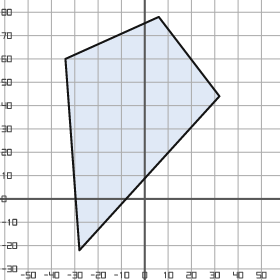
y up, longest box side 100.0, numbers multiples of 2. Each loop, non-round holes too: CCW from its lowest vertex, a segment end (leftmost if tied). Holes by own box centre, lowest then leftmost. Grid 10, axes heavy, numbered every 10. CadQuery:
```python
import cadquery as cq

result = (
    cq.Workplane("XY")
    .moveTo(-28.0, -22.0)
    .lineTo(32.0, 44.0)
    .lineTo(6.0, 78.0)
    .lineTo(-34.0, 60.0)
    .close()
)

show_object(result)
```